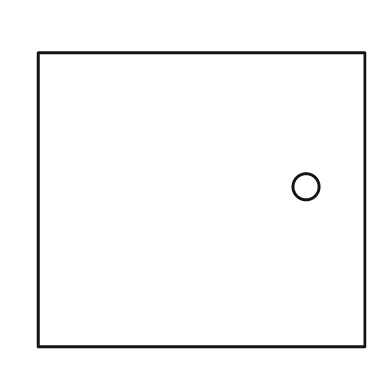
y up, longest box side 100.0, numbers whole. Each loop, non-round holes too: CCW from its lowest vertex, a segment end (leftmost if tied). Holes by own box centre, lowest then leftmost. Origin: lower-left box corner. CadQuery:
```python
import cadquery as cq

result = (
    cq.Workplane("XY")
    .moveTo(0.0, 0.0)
    .lineTo(100.0, 0.0)
    .lineTo(100.0, 90.0)
    .lineTo(0.0, 90.0)
    .close()
    .moveTo(82.0, 49.0)
    .circle(4.0)
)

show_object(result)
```